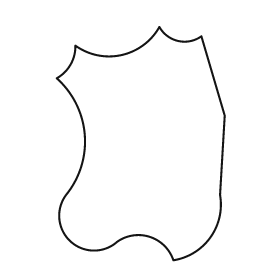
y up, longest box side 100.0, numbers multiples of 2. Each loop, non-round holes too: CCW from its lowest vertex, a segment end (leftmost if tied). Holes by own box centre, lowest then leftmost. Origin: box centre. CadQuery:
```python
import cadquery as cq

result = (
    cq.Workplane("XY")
    .moveTo(14.0, -50.0)
    .threePointArc((30.0, -40.0), (34.0, -22.0))
    .lineTo(36.0, 12.0)
    .lineTo(26.0, 46.0)
    .threePointArc((16.0, 44.0), (8.0, 50.0))
    .threePointArc((-8.0, 38.0), (-28.0, 42.0))
    .threePointArc((-30.0, 34.0), (-36.0, 28.0))
    .threePointArc((-24.0, 4.0), (-32.0, -22.0))
    .threePointArc((-30.0, -42.0), (-10.0, -42.0))
    .threePointArc((4.0, -40.0), (14.0, -50.0))
    .close()
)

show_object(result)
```